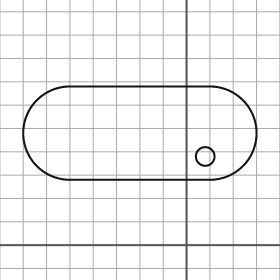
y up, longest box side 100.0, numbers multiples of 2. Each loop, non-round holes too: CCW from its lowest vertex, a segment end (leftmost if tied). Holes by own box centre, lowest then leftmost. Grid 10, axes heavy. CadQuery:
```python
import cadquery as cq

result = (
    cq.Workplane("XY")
    .moveTo(-50.0, 28.0)
    .lineTo(10.0, 28.0)
    .threePointArc((30.0, 48.0), (10.0, 68.0))
    .lineTo(-50.0, 68.0)
    .threePointArc((-70.0, 48.0), (-50.0, 28.0))
    .close()
    .moveTo(8.0, 38.0)
    .circle(4.0)
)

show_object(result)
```